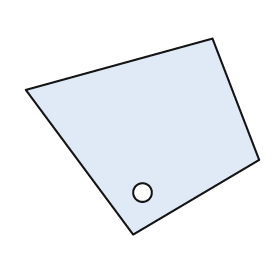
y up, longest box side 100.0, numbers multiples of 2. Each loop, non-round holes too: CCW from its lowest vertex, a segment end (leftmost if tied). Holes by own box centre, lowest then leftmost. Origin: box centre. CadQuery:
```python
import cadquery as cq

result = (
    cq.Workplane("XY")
    .moveTo(-4.0, -42.0)
    .lineTo(50.0, -10.0)
    .lineTo(30.0, 42.0)
    .lineTo(-50.0, 20.0)
    .close()
    .moveTo(0.0, -24.0)
    .circle(4.0)
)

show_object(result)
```